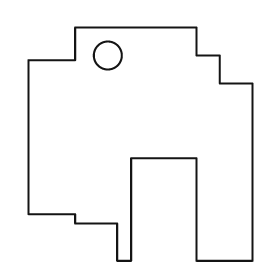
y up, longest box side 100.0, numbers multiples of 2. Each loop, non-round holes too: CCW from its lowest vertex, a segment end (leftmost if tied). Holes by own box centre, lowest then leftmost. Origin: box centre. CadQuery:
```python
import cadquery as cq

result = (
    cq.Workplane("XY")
    .moveTo(-10.0, -50.0)
    .lineTo(-4.0, -50.0)
    .lineTo(-4.0, -6.0)
    .lineTo(24.0, -6.0)
    .lineTo(24.0, -50.0)
    .lineTo(48.0, -50.0)
    .lineTo(48.0, 26.0)
    .lineTo(34.0, 26.0)
    .lineTo(34.0, 38.0)
    .lineTo(24.0, 38.0)
    .lineTo(24.0, 50.0)
    .lineTo(-28.0, 50.0)
    .lineTo(-28.0, 36.0)
    .lineTo(-48.0, 36.0)
    .lineTo(-48.0, -30.0)
    .lineTo(-28.0, -30.0)
    .lineTo(-28.0, -34.0)
    .lineTo(-10.0, -34.0)
    .close()
    .moveTo(-14.0, 38.0)
    .circle(6.0)
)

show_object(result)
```